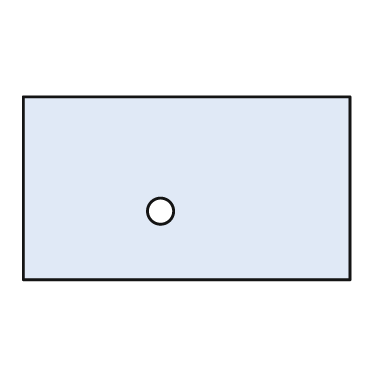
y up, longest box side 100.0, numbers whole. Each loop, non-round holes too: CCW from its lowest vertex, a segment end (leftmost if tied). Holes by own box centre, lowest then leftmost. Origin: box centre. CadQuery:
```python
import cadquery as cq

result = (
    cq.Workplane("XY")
    .moveTo(-50.0, -28.0)
    .lineTo(50.0, -28.0)
    .lineTo(50.0, 28.0)
    .lineTo(-50.0, 28.0)
    .close()
    .moveTo(-8.0, -7.0)
    .circle(4.0)
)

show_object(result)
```